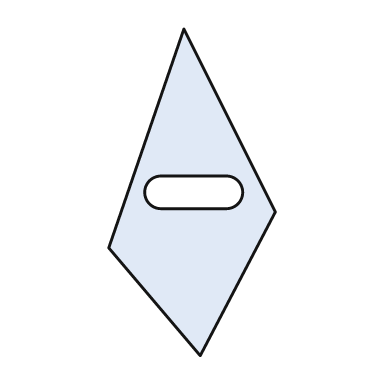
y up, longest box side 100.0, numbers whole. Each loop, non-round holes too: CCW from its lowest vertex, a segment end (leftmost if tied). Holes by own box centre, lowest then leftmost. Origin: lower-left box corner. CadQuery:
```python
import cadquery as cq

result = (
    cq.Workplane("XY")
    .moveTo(28.0, 0.0)
    .lineTo(51.0, 44.0)
    .lineTo(23.0, 100.0)
    .lineTo(0.0, 33.0)
    .close()
    .moveTo(16.0, 45.0)
    .lineTo(36.0, 45.0)
    .threePointArc((41.0, 50.0), (36.0, 55.0))
    .lineTo(16.0, 55.0)
    .threePointArc((11.0, 50.0), (16.0, 45.0))
    .close()
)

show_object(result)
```